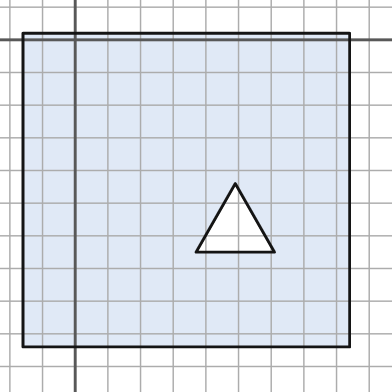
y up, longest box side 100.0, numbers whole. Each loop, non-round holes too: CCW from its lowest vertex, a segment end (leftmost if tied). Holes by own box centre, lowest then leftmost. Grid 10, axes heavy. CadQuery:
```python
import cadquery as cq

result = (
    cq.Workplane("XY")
    .moveTo(-16.0, -94.0)
    .lineTo(84.0, -94.0)
    .lineTo(84.0, 2.0)
    .lineTo(-16.0, 2.0)
    .close()
    .moveTo(37.0, -65.0)
    .lineTo(61.0, -65.0)
    .lineTo(49.0, -44.0)
    .close()
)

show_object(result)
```